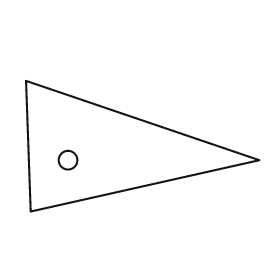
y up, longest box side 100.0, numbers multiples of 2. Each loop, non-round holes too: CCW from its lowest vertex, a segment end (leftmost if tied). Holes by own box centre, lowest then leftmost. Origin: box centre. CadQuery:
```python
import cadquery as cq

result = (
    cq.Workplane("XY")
    .moveTo(-48.0, -28.0)
    .lineTo(50.0, -6.0)
    .lineTo(-50.0, 28.0)
    .close()
    .moveTo(-32.0, -6.0)
    .circle(4.0)
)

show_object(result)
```